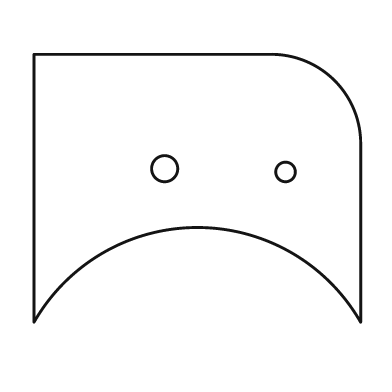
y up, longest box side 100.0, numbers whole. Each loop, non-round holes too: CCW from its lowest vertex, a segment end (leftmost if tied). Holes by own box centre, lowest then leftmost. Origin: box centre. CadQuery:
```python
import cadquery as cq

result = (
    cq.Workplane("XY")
    .moveTo(-50.0, -41.0)
    .threePointArc((0.0, -12.0), (50.0, -41.0))
    .lineTo(50.0, 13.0)
    .threePointArc((42.0, 33.0), (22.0, 41.0))
    .lineTo(-50.0, 41.0)
    .close()
    .moveTo(27.0, 5.0)
    .circle(3.0)
    .moveTo(-10.0, 6.0)
    .circle(4.0)
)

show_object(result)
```